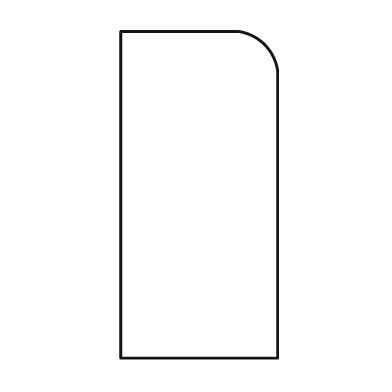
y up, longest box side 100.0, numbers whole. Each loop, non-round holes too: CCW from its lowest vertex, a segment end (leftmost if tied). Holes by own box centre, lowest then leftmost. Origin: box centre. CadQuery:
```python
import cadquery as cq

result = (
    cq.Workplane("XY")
    .moveTo(-24.0, -50.0)
    .lineTo(24.0, -50.0)
    .lineTo(24.0, 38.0)
    .threePointArc((20.0, 46.0), (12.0, 50.0))
    .lineTo(-24.0, 50.0)
    .close()
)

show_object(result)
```